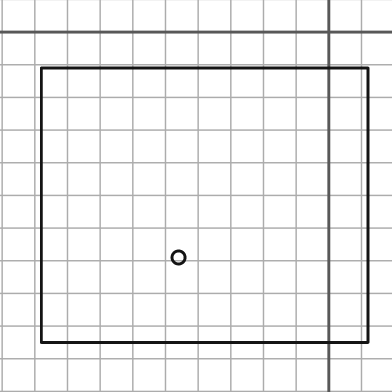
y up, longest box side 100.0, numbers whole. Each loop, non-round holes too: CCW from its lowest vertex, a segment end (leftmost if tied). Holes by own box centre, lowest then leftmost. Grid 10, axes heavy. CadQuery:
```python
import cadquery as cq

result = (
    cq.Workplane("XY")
    .moveTo(-88.0, -95.0)
    .lineTo(12.0, -95.0)
    .lineTo(12.0, -11.0)
    .lineTo(-88.0, -11.0)
    .close()
    .moveTo(-46.0, -69.0)
    .circle(2.0)
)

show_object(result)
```